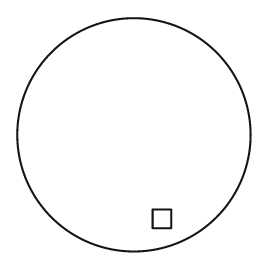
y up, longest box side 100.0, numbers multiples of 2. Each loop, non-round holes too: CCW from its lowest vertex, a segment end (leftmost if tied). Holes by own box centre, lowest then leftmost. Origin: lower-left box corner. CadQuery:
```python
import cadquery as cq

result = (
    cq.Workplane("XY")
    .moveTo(50.0, 50.0)
    .circle(50.0)
    .moveTo(58.0, 10.0)
    .lineTo(66.0, 10.0)
    .lineTo(66.0, 18.0)
    .lineTo(58.0, 18.0)
    .close()
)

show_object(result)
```